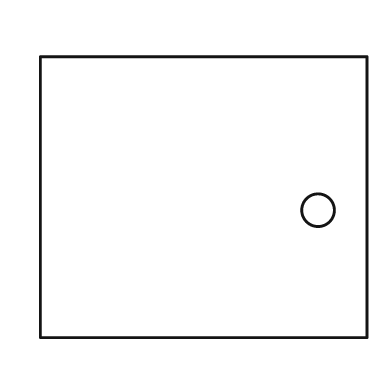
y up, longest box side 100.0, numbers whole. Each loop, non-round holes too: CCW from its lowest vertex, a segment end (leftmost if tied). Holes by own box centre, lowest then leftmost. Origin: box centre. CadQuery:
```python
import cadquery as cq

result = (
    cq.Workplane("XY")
    .moveTo(-50.0, -43.0)
    .lineTo(50.0, -43.0)
    .lineTo(50.0, 43.0)
    .lineTo(-50.0, 43.0)
    .close()
    .moveTo(35.0, -4.0)
    .circle(5.0)
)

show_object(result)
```